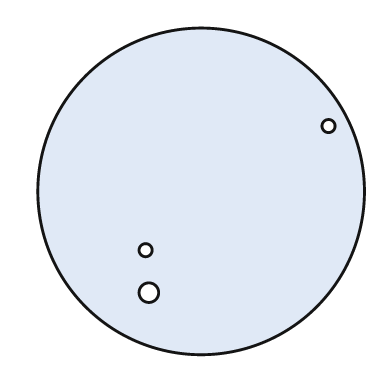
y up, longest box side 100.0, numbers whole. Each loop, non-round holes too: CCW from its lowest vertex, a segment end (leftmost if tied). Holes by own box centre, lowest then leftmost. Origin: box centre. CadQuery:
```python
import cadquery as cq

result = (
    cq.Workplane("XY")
    .moveTo(0.0, 0.0)
    .circle(50.0)
    .moveTo(-16.0, -31.0)
    .circle(3.0)
    .moveTo(-17.0, -18.0)
    .circle(2.0)
    .moveTo(39.0, 20.0)
    .circle(2.0)
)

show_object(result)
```